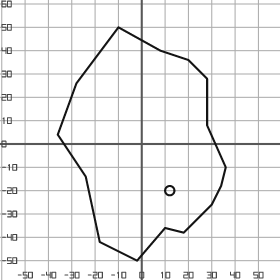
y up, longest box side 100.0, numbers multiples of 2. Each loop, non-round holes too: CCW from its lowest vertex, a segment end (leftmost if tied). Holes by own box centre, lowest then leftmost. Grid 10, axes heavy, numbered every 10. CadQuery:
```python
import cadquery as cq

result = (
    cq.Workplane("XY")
    .moveTo(-2.0, -50.0)
    .lineTo(10.0, -36.0)
    .lineTo(18.0, -38.0)
    .lineTo(30.0, -26.0)
    .lineTo(34.0, -18.0)
    .lineTo(36.0, -10.0)
    .lineTo(28.0, 8.0)
    .lineTo(28.0, 28.0)
    .lineTo(20.0, 36.0)
    .lineTo(8.0, 40.0)
    .lineTo(-10.0, 50.0)
    .lineTo(-28.0, 26.0)
    .lineTo(-36.0, 4.0)
    .lineTo(-24.0, -14.0)
    .lineTo(-18.0, -42.0)
    .close()
    .moveTo(12.0, -20.0)
    .circle(2.0)
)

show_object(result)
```